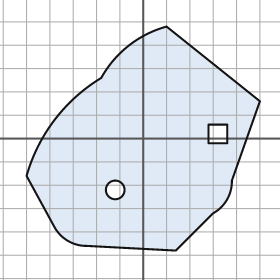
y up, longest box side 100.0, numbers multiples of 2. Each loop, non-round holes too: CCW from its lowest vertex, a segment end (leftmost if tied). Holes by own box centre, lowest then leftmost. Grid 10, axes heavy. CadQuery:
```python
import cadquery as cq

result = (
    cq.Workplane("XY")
    .moveTo(14.0, -48.0)
    .lineTo(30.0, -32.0)
    .threePointArc((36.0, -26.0), (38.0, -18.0))
    .lineTo(50.0, 16.0)
    .lineTo(10.0, 48.0)
    .threePointArc((-6.0, 40.0), (-18.0, 26.0))
    .threePointArc((-38.0, 8.0), (-50.0, -16.0))
    .lineTo(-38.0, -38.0)
    .threePointArc((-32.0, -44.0), (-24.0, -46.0))
    .close()
    .moveTo(-12.0, -22.0)
    .circle(4.0)
    .moveTo(28.0, -2.0)
    .lineTo(36.0, -2.0)
    .lineTo(36.0, 6.0)
    .lineTo(28.0, 6.0)
    .close()
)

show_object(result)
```